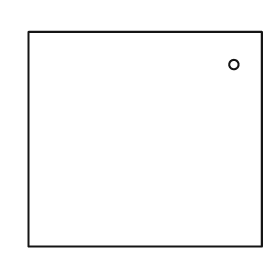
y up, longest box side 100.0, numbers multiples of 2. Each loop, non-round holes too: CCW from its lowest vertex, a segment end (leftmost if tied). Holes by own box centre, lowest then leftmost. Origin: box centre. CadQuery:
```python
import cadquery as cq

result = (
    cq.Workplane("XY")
    .moveTo(-50.0, -46.0)
    .lineTo(50.0, -46.0)
    .lineTo(50.0, 46.0)
    .lineTo(-50.0, 46.0)
    .close()
    .moveTo(38.0, 32.0)
    .circle(2.0)
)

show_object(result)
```